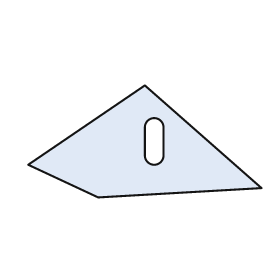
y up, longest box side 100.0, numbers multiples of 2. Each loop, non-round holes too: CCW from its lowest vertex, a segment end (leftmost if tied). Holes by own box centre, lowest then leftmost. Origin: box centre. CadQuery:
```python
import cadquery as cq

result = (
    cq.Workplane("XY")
    .moveTo(-20.0, -24.0)
    .lineTo(50.0, -20.0)
    .lineTo(0.0, 24.0)
    .lineTo(-50.0, -10.0)
    .close()
    .moveTo(0.0, -6.0)
    .threePointArc((4.0, -10.0), (8.0, -6.0))
    .lineTo(8.0, 6.0)
    .threePointArc((4.0, 10.0), (0.0, 6.0))
    .close()
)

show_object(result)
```